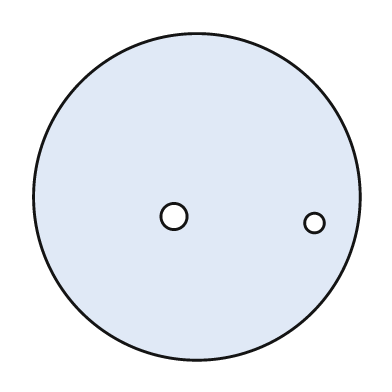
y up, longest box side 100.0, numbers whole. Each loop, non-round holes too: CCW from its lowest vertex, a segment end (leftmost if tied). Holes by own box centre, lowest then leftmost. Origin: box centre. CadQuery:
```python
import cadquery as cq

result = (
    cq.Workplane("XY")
    .moveTo(0.0, 0.0)
    .circle(50.0)
    .moveTo(36.0, -8.0)
    .circle(3.0)
    .moveTo(-7.0, -6.0)
    .circle(4.0)
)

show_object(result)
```